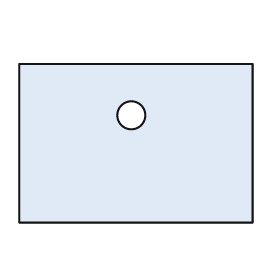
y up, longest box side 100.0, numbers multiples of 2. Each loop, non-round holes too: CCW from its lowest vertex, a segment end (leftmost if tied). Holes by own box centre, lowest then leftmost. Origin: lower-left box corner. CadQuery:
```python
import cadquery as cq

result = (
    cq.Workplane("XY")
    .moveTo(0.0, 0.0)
    .lineTo(100.0, 0.0)
    .lineTo(100.0, 68.0)
    .lineTo(0.0, 68.0)
    .close()
    .moveTo(48.0, 46.0)
    .circle(6.0)
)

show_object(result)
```